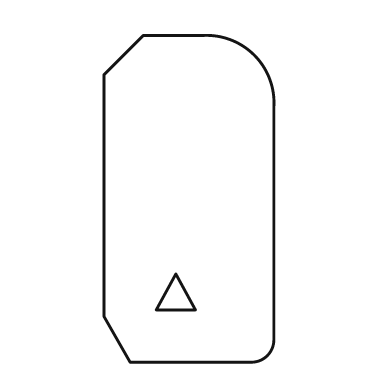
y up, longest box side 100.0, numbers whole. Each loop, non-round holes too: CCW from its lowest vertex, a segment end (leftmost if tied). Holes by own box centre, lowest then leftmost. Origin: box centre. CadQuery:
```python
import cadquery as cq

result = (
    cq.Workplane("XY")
    .moveTo(-18.0, -50.0)
    .lineTo(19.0, -50.0)
    .threePointArc((24.0, -48.0), (26.0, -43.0))
    .lineTo(26.0, 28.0)
    .threePointArc((20.0, 44.0), (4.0, 50.0))
    .lineTo(-14.0, 50.0)
    .lineTo(-26.0, 38.0)
    .lineTo(-26.0, -36.0)
    .close()
    .moveTo(-10.0, -34.0)
    .lineTo(2.0, -34.0)
    .lineTo(-4.0, -23.0)
    .close()
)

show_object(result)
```